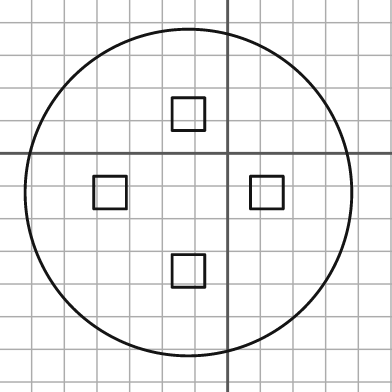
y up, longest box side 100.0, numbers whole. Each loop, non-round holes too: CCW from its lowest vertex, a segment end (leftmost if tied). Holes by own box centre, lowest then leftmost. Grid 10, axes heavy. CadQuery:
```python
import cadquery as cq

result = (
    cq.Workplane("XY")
    .moveTo(-12.0, -12.0)
    .circle(50.0)
    .moveTo(-17.0, -41.0)
    .lineTo(-7.0, -41.0)
    .lineTo(-7.0, -31.0)
    .lineTo(-17.0, -31.0)
    .close()
    .moveTo(-41.0, -17.0)
    .lineTo(-31.0, -17.0)
    .lineTo(-31.0, -7.0)
    .lineTo(-41.0, -7.0)
    .close()
    .moveTo(7.0, -17.0)
    .lineTo(17.0, -17.0)
    .lineTo(17.0, -7.0)
    .lineTo(7.0, -7.0)
    .close()
    .moveTo(-17.0, 7.0)
    .lineTo(-7.0, 7.0)
    .lineTo(-7.0, 17.0)
    .lineTo(-17.0, 17.0)
    .close()
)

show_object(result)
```